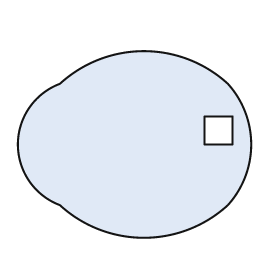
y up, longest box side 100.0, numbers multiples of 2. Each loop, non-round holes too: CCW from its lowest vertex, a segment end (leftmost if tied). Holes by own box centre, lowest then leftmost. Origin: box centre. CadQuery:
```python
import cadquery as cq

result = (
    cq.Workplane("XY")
    .moveTo(-32.0, -26.0)
    .threePointArc((4.0, -40.0), (40.0, -26.0))
    .threePointArc((50.0, 0.0), (40.0, 26.0))
    .threePointArc((4.0, 40.0), (-32.0, 26.0))
    .threePointArc((-50.0, 0.0), (-32.0, -26.0))
    .close()
    .moveTo(30.0, 0.0)
    .lineTo(42.0, 0.0)
    .lineTo(42.0, 12.0)
    .lineTo(30.0, 12.0)
    .close()
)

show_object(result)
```